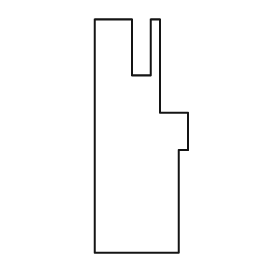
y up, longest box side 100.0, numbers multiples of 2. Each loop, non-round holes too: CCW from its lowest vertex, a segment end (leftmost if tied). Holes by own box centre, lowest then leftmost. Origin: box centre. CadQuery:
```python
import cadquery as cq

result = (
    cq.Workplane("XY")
    .moveTo(-20.0, -50.0)
    .lineTo(16.0, -50.0)
    .lineTo(16.0, -6.0)
    .lineTo(20.0, -6.0)
    .lineTo(20.0, 10.0)
    .lineTo(8.0, 10.0)
    .lineTo(8.0, 50.0)
    .lineTo(4.0, 50.0)
    .lineTo(4.0, 26.0)
    .lineTo(-4.0, 26.0)
    .lineTo(-4.0, 50.0)
    .lineTo(-20.0, 50.0)
    .close()
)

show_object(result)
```